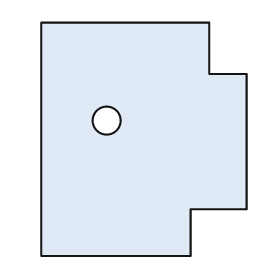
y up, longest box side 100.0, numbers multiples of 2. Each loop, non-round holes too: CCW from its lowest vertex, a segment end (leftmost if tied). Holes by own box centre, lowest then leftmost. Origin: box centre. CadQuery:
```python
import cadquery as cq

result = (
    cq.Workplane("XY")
    .moveTo(-44.0, -50.0)
    .lineTo(20.0, -50.0)
    .lineTo(20.0, -30.0)
    .lineTo(44.0, -30.0)
    .lineTo(44.0, 28.0)
    .lineTo(28.0, 28.0)
    .lineTo(28.0, 50.0)
    .lineTo(-44.0, 50.0)
    .close()
    .moveTo(-16.0, 8.0)
    .circle(6.0)
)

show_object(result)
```